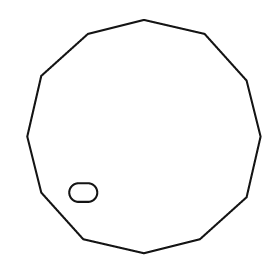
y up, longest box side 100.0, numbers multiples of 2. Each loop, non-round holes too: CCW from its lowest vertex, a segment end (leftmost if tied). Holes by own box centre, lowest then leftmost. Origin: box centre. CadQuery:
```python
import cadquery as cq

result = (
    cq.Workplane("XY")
    .moveTo(0.0, -50.0)
    .lineTo(24.0, -44.0)
    .lineTo(44.0, -26.0)
    .lineTo(50.0, 0.0)
    .lineTo(44.0, 24.0)
    .lineTo(26.0, 44.0)
    .lineTo(0.0, 50.0)
    .lineTo(-24.0, 44.0)
    .lineTo(-44.0, 26.0)
    .lineTo(-50.0, 0.0)
    .lineTo(-44.0, -24.0)
    .lineTo(-26.0, -44.0)
    .close()
    .moveTo(-28.0, -28.0)
    .lineTo(-24.0, -28.0)
    .threePointArc((-20.0, -24.0), (-24.0, -20.0))
    .lineTo(-28.0, -20.0)
    .threePointArc((-32.0, -24.0), (-28.0, -28.0))
    .close()
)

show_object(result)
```